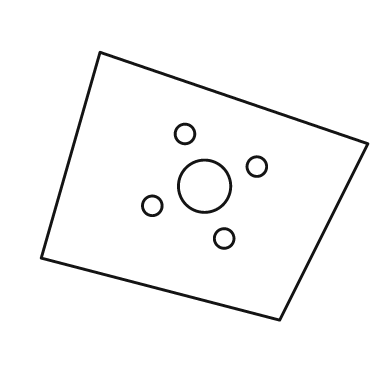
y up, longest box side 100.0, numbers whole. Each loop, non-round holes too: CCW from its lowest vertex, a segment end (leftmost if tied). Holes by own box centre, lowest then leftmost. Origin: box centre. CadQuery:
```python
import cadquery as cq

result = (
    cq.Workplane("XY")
    .moveTo(23.0, -41.0)
    .lineTo(50.0, 13.0)
    .lineTo(-32.0, 41.0)
    .lineTo(-50.0, -22.0)
    .close()
    .moveTo(6.0, -16.0)
    .circle(3.0)
    .moveTo(-16.0, -6.0)
    .circle(3.0)
    .moveTo(0.0, 0.0)
    .circle(8.0)
    .moveTo(16.0, 6.0)
    .circle(3.0)
    .moveTo(-6.0, 16.0)
    .circle(3.0)
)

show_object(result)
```